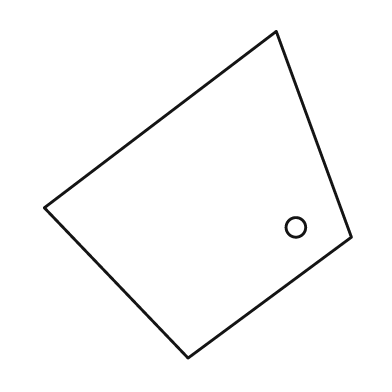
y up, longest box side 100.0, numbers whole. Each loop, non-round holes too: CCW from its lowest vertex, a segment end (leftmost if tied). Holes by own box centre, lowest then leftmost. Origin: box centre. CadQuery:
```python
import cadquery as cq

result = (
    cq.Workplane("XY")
    .moveTo(-3.0, -50.0)
    .lineTo(47.0, -13.0)
    .lineTo(24.0, 50.0)
    .lineTo(-47.0, -4.0)
    .close()
    .moveTo(30.0, -10.0)
    .circle(3.0)
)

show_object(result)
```